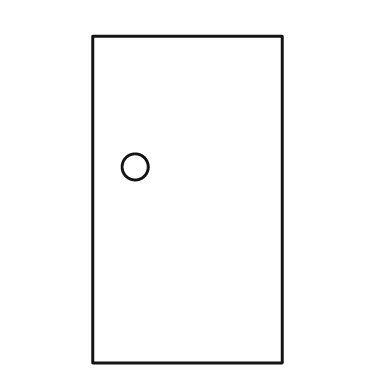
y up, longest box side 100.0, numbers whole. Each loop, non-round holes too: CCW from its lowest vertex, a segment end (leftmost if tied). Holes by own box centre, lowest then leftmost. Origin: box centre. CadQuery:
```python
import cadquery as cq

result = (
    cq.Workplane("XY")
    .moveTo(-29.0, -50.0)
    .lineTo(29.0, -50.0)
    .lineTo(29.0, 50.0)
    .lineTo(-29.0, 50.0)
    .close()
    .moveTo(-16.0, 10.0)
    .circle(4.0)
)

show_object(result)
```